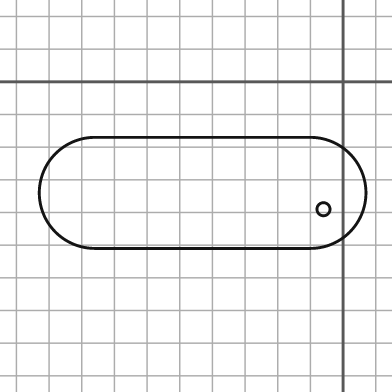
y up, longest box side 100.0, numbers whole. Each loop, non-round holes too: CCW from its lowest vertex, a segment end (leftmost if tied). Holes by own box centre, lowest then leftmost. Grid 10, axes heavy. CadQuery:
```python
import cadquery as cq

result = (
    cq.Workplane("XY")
    .moveTo(-76.0, -51.0)
    .lineTo(-10.0, -51.0)
    .threePointArc((7.0, -34.0), (-10.0, -17.0))
    .lineTo(-76.0, -17.0)
    .threePointArc((-93.0, -34.0), (-76.0, -51.0))
    .close()
    .moveTo(-6.0, -39.0)
    .circle(2.0)
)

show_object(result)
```